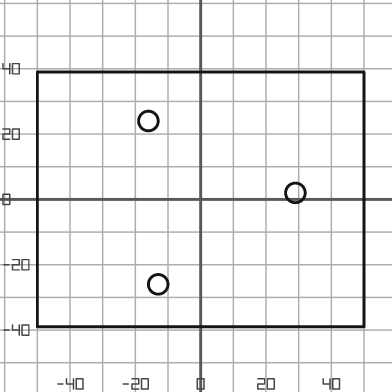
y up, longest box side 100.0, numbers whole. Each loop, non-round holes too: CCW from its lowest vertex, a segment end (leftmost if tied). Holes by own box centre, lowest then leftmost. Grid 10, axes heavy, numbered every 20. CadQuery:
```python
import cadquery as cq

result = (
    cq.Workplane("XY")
    .moveTo(-50.0, -39.0)
    .lineTo(50.0, -39.0)
    .lineTo(50.0, 39.0)
    .lineTo(-50.0, 39.0)
    .close()
    .moveTo(-13.0, -26.0)
    .circle(3.0)
    .moveTo(29.0, 2.0)
    .circle(3.0)
    .moveTo(-16.0, 24.0)
    .circle(3.0)
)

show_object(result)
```